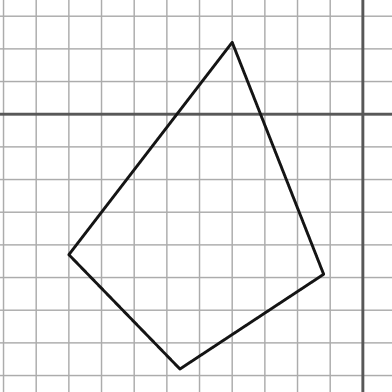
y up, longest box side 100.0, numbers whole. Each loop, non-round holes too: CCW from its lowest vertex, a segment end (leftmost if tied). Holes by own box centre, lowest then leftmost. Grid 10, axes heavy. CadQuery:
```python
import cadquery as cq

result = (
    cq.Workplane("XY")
    .moveTo(-56.0, -78.0)
    .lineTo(-12.0, -49.0)
    .lineTo(-40.0, 22.0)
    .lineTo(-90.0, -43.0)
    .close()
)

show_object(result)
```